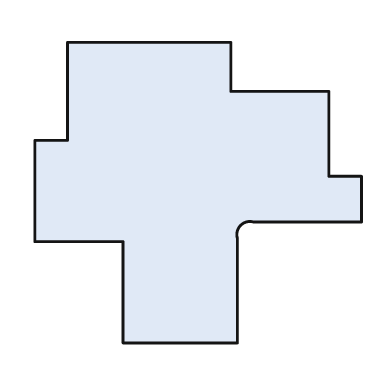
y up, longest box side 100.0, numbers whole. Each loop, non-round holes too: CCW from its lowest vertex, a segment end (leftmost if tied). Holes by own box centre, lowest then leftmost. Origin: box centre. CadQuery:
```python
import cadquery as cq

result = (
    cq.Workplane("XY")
    .moveTo(-23.0, -46.0)
    .lineTo(12.0, -46.0)
    .lineTo(12.0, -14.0)
    .threePointArc((13.0, -10.0), (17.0, -9.0))
    .lineTo(50.0, -9.0)
    .lineTo(50.0, 5.0)
    .lineTo(40.0, 5.0)
    .lineTo(40.0, 31.0)
    .lineTo(10.0, 31.0)
    .lineTo(10.0, 46.0)
    .lineTo(-40.0, 46.0)
    .lineTo(-40.0, 16.0)
    .lineTo(-50.0, 16.0)
    .lineTo(-50.0, -15.0)
    .lineTo(-23.0, -15.0)
    .close()
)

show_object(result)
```